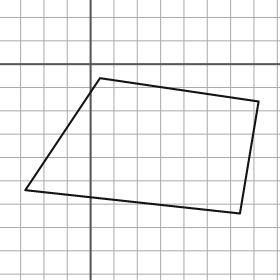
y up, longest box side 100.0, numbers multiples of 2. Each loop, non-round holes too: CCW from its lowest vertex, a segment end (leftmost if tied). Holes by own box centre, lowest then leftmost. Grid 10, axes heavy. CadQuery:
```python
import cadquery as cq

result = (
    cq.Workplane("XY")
    .moveTo(64.0, -64.0)
    .lineTo(72.0, -16.0)
    .lineTo(4.0, -6.0)
    .lineTo(-28.0, -54.0)
    .close()
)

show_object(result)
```